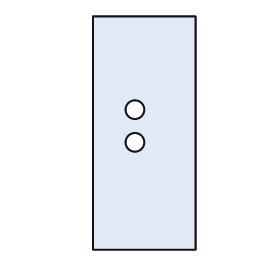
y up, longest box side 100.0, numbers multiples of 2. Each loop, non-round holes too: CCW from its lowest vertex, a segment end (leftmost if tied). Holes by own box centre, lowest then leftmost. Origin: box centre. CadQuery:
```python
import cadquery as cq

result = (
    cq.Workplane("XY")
    .moveTo(-22.0, -50.0)
    .lineTo(22.0, -50.0)
    .lineTo(22.0, 50.0)
    .lineTo(-22.0, 50.0)
    .close()
    .moveTo(-4.0, -4.0)
    .circle(4.0)
    .moveTo(-4.0, 10.0)
    .circle(4.0)
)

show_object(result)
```